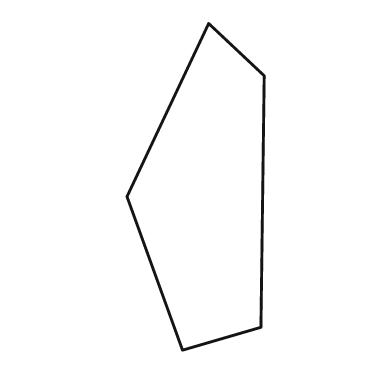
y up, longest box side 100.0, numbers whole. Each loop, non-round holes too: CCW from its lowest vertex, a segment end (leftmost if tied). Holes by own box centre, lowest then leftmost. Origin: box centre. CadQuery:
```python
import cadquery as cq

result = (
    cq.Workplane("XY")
    .moveTo(-4.0, -50.0)
    .lineTo(20.0, -43.0)
    .lineTo(21.0, 34.0)
    .lineTo(4.0, 50.0)
    .lineTo(-21.0, -3.0)
    .close()
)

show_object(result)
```